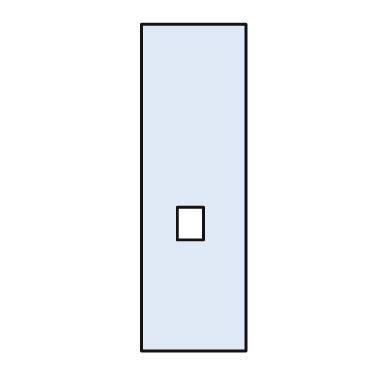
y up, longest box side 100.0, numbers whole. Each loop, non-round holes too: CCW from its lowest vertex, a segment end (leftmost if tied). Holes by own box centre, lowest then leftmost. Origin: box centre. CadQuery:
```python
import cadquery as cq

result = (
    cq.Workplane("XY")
    .moveTo(-16.0, -50.0)
    .lineTo(16.0, -50.0)
    .lineTo(16.0, 50.0)
    .lineTo(-16.0, 50.0)
    .close()
    .moveTo(-5.0, -16.0)
    .lineTo(3.0, -16.0)
    .lineTo(3.0, -6.0)
    .lineTo(-5.0, -6.0)
    .close()
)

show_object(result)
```